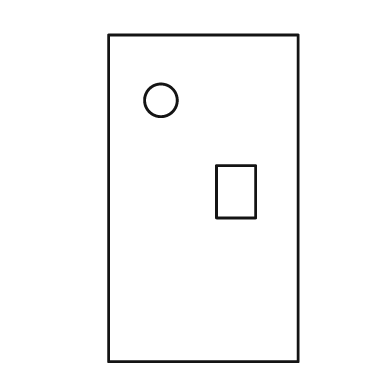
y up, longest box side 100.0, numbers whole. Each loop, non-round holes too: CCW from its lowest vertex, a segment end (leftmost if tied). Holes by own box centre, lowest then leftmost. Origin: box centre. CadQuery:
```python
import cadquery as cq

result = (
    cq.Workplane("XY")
    .moveTo(-29.0, -50.0)
    .lineTo(29.0, -50.0)
    .lineTo(29.0, 50.0)
    .lineTo(-29.0, 50.0)
    .close()
    .moveTo(4.0, -6.0)
    .lineTo(16.0, -6.0)
    .lineTo(16.0, 10.0)
    .lineTo(4.0, 10.0)
    .close()
    .moveTo(-13.0, 30.0)
    .circle(5.0)
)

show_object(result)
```